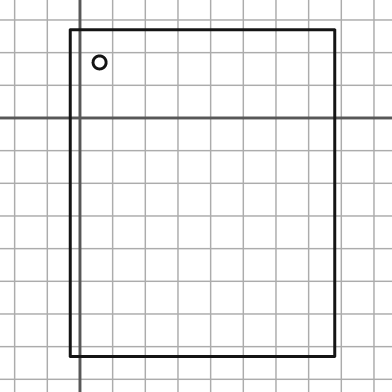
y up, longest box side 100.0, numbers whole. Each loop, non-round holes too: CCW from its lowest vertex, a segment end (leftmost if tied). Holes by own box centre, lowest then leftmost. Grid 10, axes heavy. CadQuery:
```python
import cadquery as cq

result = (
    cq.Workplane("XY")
    .moveTo(-3.0, -73.0)
    .lineTo(78.0, -73.0)
    .lineTo(78.0, 27.0)
    .lineTo(-3.0, 27.0)
    .close()
    .moveTo(6.0, 17.0)
    .circle(2.0)
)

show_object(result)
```